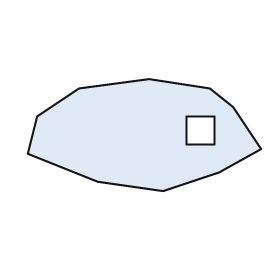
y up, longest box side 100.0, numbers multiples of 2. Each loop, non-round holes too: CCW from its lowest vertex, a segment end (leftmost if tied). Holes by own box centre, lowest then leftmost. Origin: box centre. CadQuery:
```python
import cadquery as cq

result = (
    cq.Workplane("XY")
    .moveTo(8.0, -24.0)
    .lineTo(32.0, -16.0)
    .lineTo(50.0, -6.0)
    .lineTo(38.0, 12.0)
    .lineTo(28.0, 20.0)
    .lineTo(2.0, 24.0)
    .lineTo(-28.0, 20.0)
    .lineTo(-46.0, 8.0)
    .lineTo(-50.0, -8.0)
    .lineTo(-20.0, -20.0)
    .close()
    .moveTo(18.0, -4.0)
    .lineTo(30.0, -4.0)
    .lineTo(30.0, 8.0)
    .lineTo(18.0, 8.0)
    .close()
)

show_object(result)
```